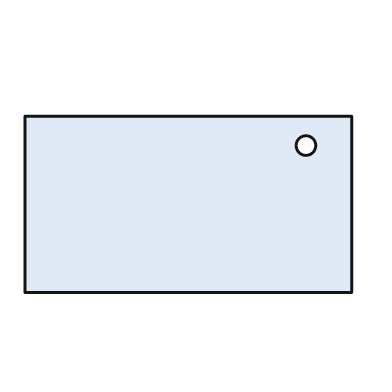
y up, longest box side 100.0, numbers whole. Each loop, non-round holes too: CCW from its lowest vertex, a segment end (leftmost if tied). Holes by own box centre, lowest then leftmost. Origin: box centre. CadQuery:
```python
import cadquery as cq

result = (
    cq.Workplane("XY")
    .moveTo(-50.0, -27.0)
    .lineTo(50.0, -27.0)
    .lineTo(50.0, 27.0)
    .lineTo(-50.0, 27.0)
    .close()
    .moveTo(36.0, 18.0)
    .circle(3.0)
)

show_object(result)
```